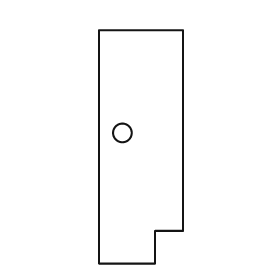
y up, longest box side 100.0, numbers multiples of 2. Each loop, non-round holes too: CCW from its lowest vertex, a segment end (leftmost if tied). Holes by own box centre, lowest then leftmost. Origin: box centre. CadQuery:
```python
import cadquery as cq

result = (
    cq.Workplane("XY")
    .moveTo(-18.0, -50.0)
    .lineTo(6.0, -50.0)
    .lineTo(6.0, -36.0)
    .lineTo(18.0, -36.0)
    .lineTo(18.0, 50.0)
    .lineTo(-18.0, 50.0)
    .close()
    .moveTo(-8.0, 6.0)
    .circle(4.0)
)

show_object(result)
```